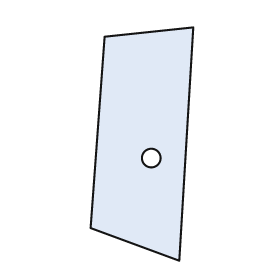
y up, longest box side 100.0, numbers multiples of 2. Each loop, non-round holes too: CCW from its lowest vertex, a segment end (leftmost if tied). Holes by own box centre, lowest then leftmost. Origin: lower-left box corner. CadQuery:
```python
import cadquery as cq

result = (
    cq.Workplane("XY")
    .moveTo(38.0, 0.0)
    .lineTo(44.0, 100.0)
    .lineTo(6.0, 96.0)
    .lineTo(0.0, 14.0)
    .close()
    .moveTo(26.0, 44.0)
    .circle(4.0)
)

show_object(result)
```